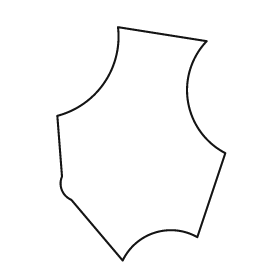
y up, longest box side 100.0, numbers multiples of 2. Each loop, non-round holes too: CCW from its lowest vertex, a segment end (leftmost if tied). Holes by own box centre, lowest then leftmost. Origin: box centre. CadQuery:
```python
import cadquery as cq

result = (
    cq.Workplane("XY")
    .moveTo(-8.0, -50.0)
    .threePointArc((6.0, -38.0), (24.0, -40.0))
    .lineTo(36.0, -4.0)
    .threePointArc((20.0, 18.0), (28.0, 44.0))
    .lineTo(-10.0, 50.0)
    .threePointArc((-16.0, 26.0), (-36.0, 12.0))
    .lineTo(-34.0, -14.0)
    .threePointArc((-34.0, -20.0), (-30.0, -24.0))
    .close()
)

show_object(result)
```